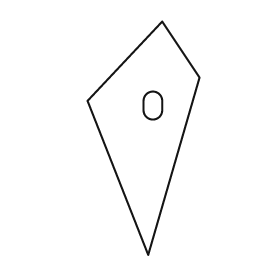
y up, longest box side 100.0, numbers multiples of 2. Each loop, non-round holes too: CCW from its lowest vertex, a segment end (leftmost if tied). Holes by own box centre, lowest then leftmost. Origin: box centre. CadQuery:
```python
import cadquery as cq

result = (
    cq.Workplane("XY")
    .moveTo(2.0, -50.0)
    .lineTo(24.0, 26.0)
    .lineTo(8.0, 50.0)
    .lineTo(-24.0, 16.0)
    .close()
    .moveTo(0.0, 12.0)
    .threePointArc((4.0, 8.0), (8.0, 12.0))
    .lineTo(8.0, 16.0)
    .threePointArc((4.0, 20.0), (0.0, 16.0))
    .close()
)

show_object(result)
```